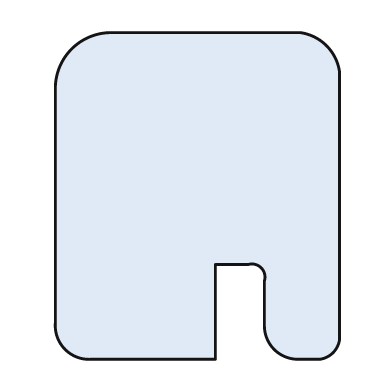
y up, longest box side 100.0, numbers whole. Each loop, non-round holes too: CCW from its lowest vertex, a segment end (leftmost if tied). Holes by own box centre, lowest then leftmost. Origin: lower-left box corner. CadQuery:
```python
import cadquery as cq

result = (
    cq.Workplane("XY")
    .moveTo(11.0, 0.0)
    .lineTo(49.0, 0.0)
    .lineTo(49.0, 29.0)
    .lineTo(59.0, 29.0)
    .threePointArc((63.0, 28.0), (64.0, 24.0))
    .lineTo(64.0, 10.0)
    .threePointArc((67.0, 3.0), (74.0, 0.0))
    .lineTo(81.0, 0.0)
    .threePointArc((85.0, 2.0), (87.0, 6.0))
    .lineTo(87.0, 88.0)
    .threePointArc((83.0, 96.0), (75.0, 100.0))
    .lineTo(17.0, 100.0)
    .threePointArc((5.0, 95.0), (0.0, 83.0))
    .lineTo(0.0, 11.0)
    .threePointArc((3.0, 3.0), (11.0, 0.0))
    .close()
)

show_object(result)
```